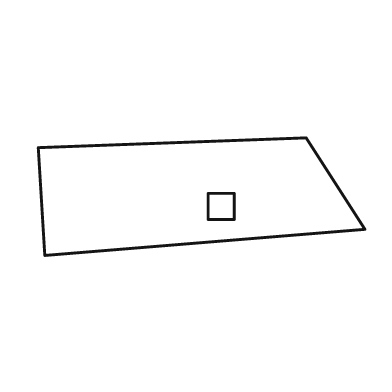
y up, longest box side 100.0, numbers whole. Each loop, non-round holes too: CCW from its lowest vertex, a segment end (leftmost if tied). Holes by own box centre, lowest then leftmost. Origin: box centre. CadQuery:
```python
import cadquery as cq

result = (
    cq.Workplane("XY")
    .moveTo(-48.0, -18.0)
    .lineTo(50.0, -10.0)
    .lineTo(32.0, 18.0)
    .lineTo(-50.0, 15.0)
    .close()
    .moveTo(2.0, -7.0)
    .lineTo(10.0, -7.0)
    .lineTo(10.0, 1.0)
    .lineTo(2.0, 1.0)
    .close()
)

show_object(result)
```